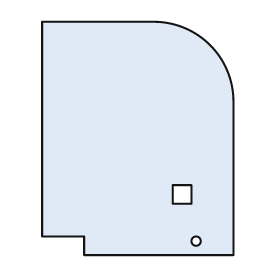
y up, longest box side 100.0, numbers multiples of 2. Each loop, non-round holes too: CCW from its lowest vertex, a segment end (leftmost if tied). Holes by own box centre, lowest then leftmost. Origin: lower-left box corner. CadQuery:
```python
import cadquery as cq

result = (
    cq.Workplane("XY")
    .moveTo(18.0, 0.0)
    .lineTo(82.0, 0.0)
    .lineTo(82.0, 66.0)
    .threePointArc((72.0, 90.0), (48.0, 100.0))
    .lineTo(0.0, 100.0)
    .lineTo(0.0, 8.0)
    .lineTo(18.0, 8.0)
    .close()
    .moveTo(66.0, 6.0)
    .circle(2.0)
    .moveTo(56.0, 22.0)
    .lineTo(64.0, 22.0)
    .lineTo(64.0, 30.0)
    .lineTo(56.0, 30.0)
    .close()
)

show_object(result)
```